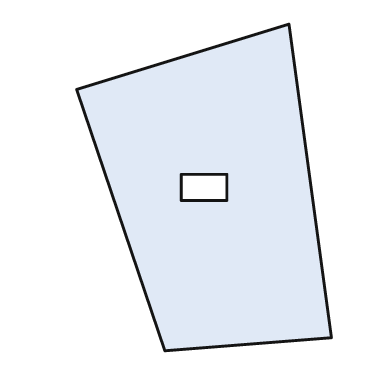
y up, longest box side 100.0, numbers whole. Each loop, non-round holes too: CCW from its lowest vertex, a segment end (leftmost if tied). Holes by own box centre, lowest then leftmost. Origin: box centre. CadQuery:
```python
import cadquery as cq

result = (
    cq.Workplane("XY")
    .moveTo(-12.0, -50.0)
    .lineTo(39.0, -46.0)
    .lineTo(26.0, 50.0)
    .lineTo(-39.0, 30.0)
    .close()
    .moveTo(-7.0, -4.0)
    .lineTo(7.0, -4.0)
    .lineTo(7.0, 4.0)
    .lineTo(-7.0, 4.0)
    .close()
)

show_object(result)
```